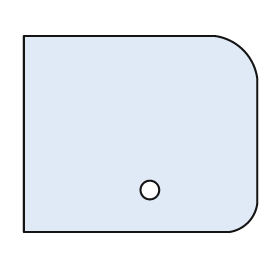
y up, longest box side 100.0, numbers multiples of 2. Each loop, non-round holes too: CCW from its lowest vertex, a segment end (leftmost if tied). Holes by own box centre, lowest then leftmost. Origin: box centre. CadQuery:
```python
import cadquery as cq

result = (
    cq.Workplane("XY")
    .moveTo(-50.0, -42.0)
    .lineTo(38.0, -42.0)
    .threePointArc((46.0, -38.0), (50.0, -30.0))
    .lineTo(50.0, 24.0)
    .threePointArc((44.0, 36.0), (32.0, 42.0))
    .lineTo(-50.0, 42.0)
    .close()
    .moveTo(4.0, -24.0)
    .circle(4.0)
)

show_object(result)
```